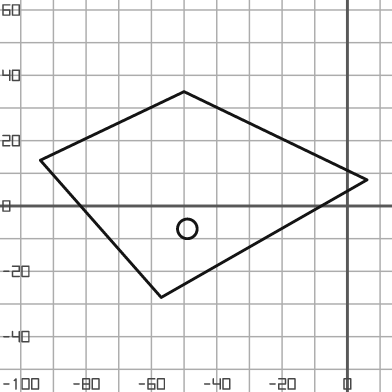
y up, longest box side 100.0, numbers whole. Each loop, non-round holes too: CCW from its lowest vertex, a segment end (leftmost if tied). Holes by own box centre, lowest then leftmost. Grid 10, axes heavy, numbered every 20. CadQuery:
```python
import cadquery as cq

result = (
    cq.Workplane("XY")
    .moveTo(-57.0, -28.0)
    .lineTo(6.0, 8.0)
    .lineTo(-50.0, 35.0)
    .lineTo(-94.0, 14.0)
    .close()
    .moveTo(-49.0, -7.0)
    .circle(3.0)
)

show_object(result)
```